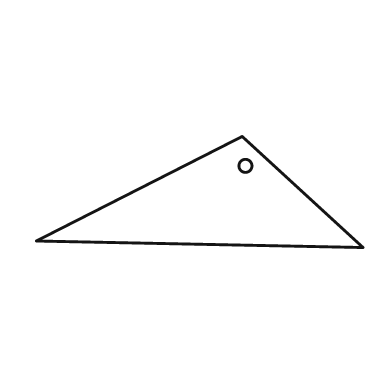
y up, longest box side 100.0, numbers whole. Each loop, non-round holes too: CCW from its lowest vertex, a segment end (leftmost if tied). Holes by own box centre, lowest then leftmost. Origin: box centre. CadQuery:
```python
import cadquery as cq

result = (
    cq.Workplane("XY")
    .moveTo(50.0, -17.0)
    .lineTo(13.0, 17.0)
    .lineTo(-50.0, -15.0)
    .close()
    .moveTo(14.0, 8.0)
    .circle(2.0)
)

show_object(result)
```